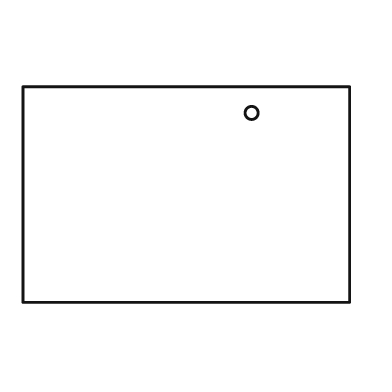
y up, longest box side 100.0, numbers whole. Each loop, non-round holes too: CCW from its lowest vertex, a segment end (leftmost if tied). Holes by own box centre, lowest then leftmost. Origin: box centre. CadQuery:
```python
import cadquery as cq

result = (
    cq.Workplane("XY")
    .moveTo(-50.0, -33.0)
    .lineTo(50.0, -33.0)
    .lineTo(50.0, 33.0)
    .lineTo(-50.0, 33.0)
    .close()
    .moveTo(20.0, 25.0)
    .circle(2.0)
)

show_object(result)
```